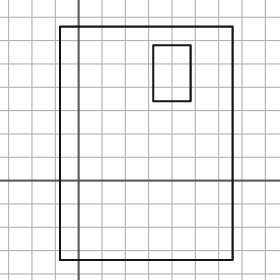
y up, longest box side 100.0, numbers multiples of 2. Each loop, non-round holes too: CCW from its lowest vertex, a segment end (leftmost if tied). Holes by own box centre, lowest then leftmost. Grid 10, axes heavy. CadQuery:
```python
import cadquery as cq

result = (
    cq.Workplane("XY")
    .moveTo(-8.0, -34.0)
    .lineTo(66.0, -34.0)
    .lineTo(66.0, 66.0)
    .lineTo(-8.0, 66.0)
    .close()
    .moveTo(32.0, 34.0)
    .lineTo(48.0, 34.0)
    .lineTo(48.0, 58.0)
    .lineTo(32.0, 58.0)
    .close()
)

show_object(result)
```